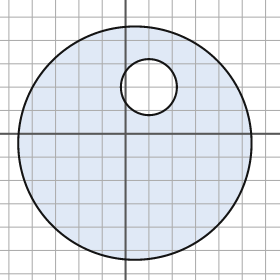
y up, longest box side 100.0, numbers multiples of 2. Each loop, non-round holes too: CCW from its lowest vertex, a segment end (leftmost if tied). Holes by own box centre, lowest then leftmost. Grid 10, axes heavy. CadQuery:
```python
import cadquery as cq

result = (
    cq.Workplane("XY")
    .moveTo(4.0, -4.0)
    .circle(50.0)
    .moveTo(10.0, 20.0)
    .circle(12.0)
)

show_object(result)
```